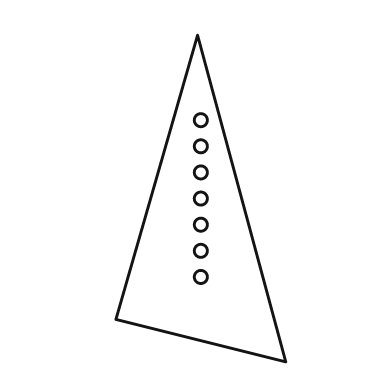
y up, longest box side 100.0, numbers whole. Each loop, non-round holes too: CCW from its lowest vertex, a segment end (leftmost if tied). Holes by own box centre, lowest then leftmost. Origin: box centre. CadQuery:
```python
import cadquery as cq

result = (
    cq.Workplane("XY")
    .moveTo(26.0, -50.0)
    .lineTo(-1.0, 50.0)
    .lineTo(-26.0, -37.0)
    .close()
    .moveTo(0.0, -24.0)
    .circle(2.0)
    .moveTo(0.0, -16.0)
    .circle(2.0)
    .moveTo(0.0, -8.0)
    .circle(2.0)
    .moveTo(0.0, 0.0)
    .circle(2.0)
    .moveTo(0.0, 8.0)
    .circle(2.0)
    .moveTo(0.0, 16.0)
    .circle(2.0)
    .moveTo(0.0, 24.0)
    .circle(2.0)
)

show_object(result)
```